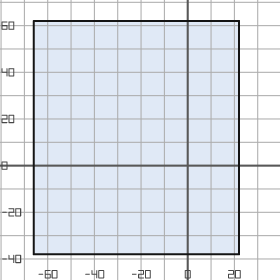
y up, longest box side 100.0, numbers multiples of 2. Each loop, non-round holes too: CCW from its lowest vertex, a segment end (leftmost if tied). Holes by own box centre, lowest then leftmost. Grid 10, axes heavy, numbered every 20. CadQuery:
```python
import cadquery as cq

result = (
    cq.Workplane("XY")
    .moveTo(-66.0, -38.0)
    .lineTo(22.0, -38.0)
    .lineTo(22.0, 62.0)
    .lineTo(-66.0, 62.0)
    .close()
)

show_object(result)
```